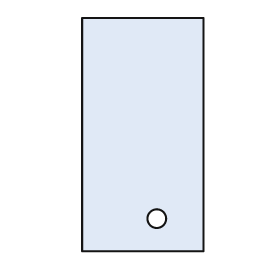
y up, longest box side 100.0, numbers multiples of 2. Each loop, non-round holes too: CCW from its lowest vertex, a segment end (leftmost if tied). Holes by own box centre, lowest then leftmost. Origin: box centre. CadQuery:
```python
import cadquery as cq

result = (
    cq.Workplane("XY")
    .moveTo(-26.0, -50.0)
    .lineTo(26.0, -50.0)
    .lineTo(26.0, 50.0)
    .lineTo(-26.0, 50.0)
    .close()
    .moveTo(6.0, -36.0)
    .circle(4.0)
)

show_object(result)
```